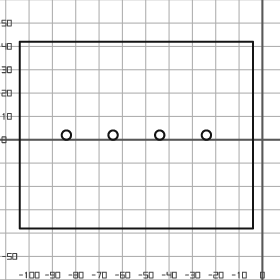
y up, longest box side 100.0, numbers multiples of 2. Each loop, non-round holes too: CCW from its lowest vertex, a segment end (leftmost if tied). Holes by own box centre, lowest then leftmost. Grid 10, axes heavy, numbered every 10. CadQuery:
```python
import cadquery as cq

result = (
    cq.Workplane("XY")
    .moveTo(-104.0, -38.0)
    .lineTo(-4.0, -38.0)
    .lineTo(-4.0, 42.0)
    .lineTo(-104.0, 42.0)
    .close()
    .moveTo(-84.0, 2.0)
    .circle(2.0)
    .moveTo(-64.0, 2.0)
    .circle(2.0)
    .moveTo(-44.0, 2.0)
    .circle(2.0)
    .moveTo(-24.0, 2.0)
    .circle(2.0)
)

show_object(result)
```